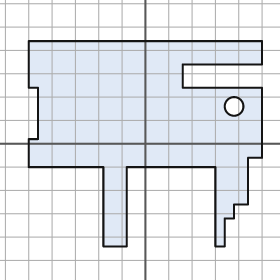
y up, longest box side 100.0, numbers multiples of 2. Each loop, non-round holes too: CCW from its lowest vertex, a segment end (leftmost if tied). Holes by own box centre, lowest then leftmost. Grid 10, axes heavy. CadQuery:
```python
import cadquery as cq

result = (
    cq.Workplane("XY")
    .moveTo(-18.0, -44.0)
    .lineTo(-8.0, -44.0)
    .lineTo(-8.0, -10.0)
    .lineTo(30.0, -10.0)
    .lineTo(30.0, -44.0)
    .lineTo(34.0, -44.0)
    .lineTo(34.0, -32.0)
    .lineTo(38.0, -32.0)
    .lineTo(38.0, -26.0)
    .lineTo(44.0, -26.0)
    .lineTo(44.0, -6.0)
    .lineTo(50.0, -6.0)
    .lineTo(50.0, 24.0)
    .lineTo(16.0, 24.0)
    .lineTo(16.0, 34.0)
    .lineTo(50.0, 34.0)
    .lineTo(50.0, 44.0)
    .lineTo(-50.0, 44.0)
    .lineTo(-50.0, 24.0)
    .lineTo(-46.0, 24.0)
    .lineTo(-46.0, 2.0)
    .lineTo(-50.0, 2.0)
    .lineTo(-50.0, -10.0)
    .lineTo(-18.0, -10.0)
    .close()
    .moveTo(38.0, 16.0)
    .circle(4.0)
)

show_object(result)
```